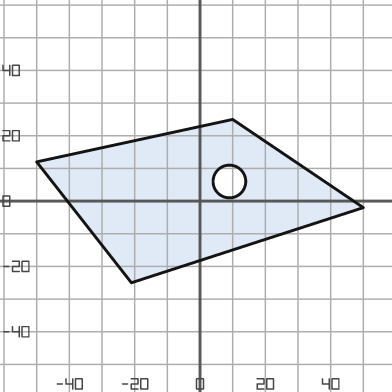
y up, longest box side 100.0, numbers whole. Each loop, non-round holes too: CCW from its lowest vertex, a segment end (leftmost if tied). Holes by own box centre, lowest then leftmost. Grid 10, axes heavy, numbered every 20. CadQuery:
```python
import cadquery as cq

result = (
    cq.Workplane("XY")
    .moveTo(-21.0, -25.0)
    .lineTo(50.0, -2.0)
    .lineTo(10.0, 25.0)
    .lineTo(-50.0, 12.0)
    .close()
    .moveTo(9.0, 6.0)
    .circle(5.0)
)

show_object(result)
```